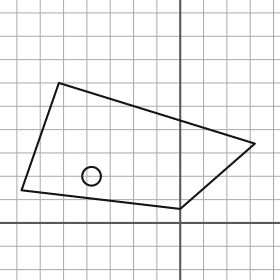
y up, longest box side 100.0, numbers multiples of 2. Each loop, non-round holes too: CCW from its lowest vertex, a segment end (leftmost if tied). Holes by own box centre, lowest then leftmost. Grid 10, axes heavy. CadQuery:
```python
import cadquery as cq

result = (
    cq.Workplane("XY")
    .moveTo(0.0, 6.0)
    .lineTo(32.0, 34.0)
    .lineTo(-52.0, 60.0)
    .lineTo(-68.0, 14.0)
    .close()
    .moveTo(-38.0, 20.0)
    .circle(4.0)
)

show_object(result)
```